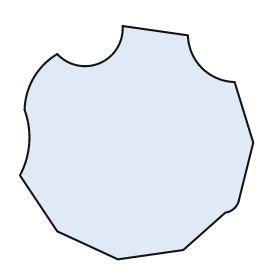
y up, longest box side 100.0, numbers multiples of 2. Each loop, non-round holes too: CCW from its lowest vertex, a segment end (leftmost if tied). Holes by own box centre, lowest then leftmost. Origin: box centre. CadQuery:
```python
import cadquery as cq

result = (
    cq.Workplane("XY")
    .moveTo(-8.0, -50.0)
    .lineTo(20.0, -46.0)
    .lineTo(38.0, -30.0)
    .threePointArc((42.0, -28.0), (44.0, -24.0))
    .lineTo(50.0, 0.0)
    .lineTo(42.0, 26.0)
    .threePointArc((28.0, 32.0), (22.0, 46.0))
    .lineTo(-6.0, 50.0)
    .threePointArc((-16.0, 34.0), (-34.0, 38.0))
    .threePointArc((-44.0, 28.0), (-48.0, 14.0))
    .threePointArc((-46.0, 0.0), (-50.0, -14.0))
    .lineTo(-34.0, -38.0)
    .close()
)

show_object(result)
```